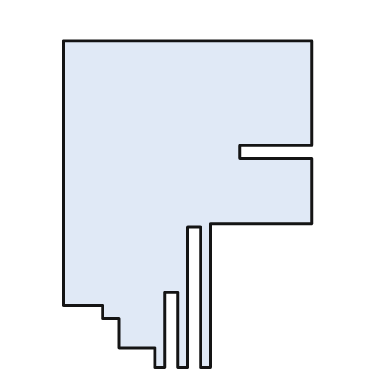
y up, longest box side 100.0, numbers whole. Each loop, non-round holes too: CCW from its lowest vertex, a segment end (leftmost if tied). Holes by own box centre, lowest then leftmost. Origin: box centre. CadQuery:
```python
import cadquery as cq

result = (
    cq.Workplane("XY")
    .moveTo(-10.0, -50.0)
    .lineTo(-7.0, -50.0)
    .lineTo(-7.0, -27.0)
    .lineTo(-3.0, -27.0)
    .lineTo(-3.0, -50.0)
    .lineTo(0.0, -50.0)
    .lineTo(0.0, -7.0)
    .lineTo(4.0, -7.0)
    .lineTo(4.0, -50.0)
    .lineTo(7.0, -50.0)
    .lineTo(7.0, -6.0)
    .lineTo(38.0, -6.0)
    .lineTo(38.0, 14.0)
    .lineTo(16.0, 14.0)
    .lineTo(16.0, 18.0)
    .lineTo(38.0, 18.0)
    .lineTo(38.0, 50.0)
    .lineTo(-38.0, 50.0)
    .lineTo(-38.0, -31.0)
    .lineTo(-26.0, -31.0)
    .lineTo(-26.0, -35.0)
    .lineTo(-21.0, -35.0)
    .lineTo(-21.0, -44.0)
    .lineTo(-10.0, -44.0)
    .close()
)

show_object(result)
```